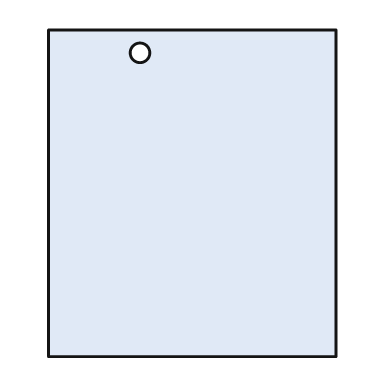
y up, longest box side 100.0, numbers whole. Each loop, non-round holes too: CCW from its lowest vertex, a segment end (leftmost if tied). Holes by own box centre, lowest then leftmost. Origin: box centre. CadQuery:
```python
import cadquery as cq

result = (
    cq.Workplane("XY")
    .moveTo(-44.0, -50.0)
    .lineTo(44.0, -50.0)
    .lineTo(44.0, 50.0)
    .lineTo(-44.0, 50.0)
    .close()
    .moveTo(-16.0, 43.0)
    .circle(3.0)
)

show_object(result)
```